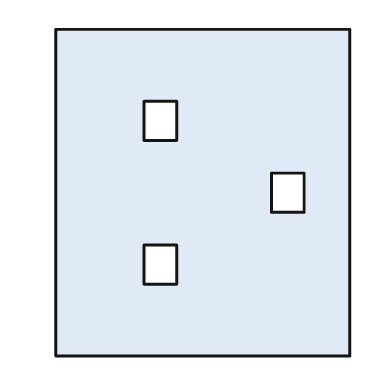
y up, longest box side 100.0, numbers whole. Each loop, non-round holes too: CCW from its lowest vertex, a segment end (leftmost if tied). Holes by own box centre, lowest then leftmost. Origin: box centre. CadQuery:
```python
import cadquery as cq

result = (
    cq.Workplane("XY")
    .moveTo(-45.0, -50.0)
    .lineTo(45.0, -50.0)
    .lineTo(45.0, 50.0)
    .lineTo(-45.0, 50.0)
    .close()
    .moveTo(-18.0, -28.0)
    .lineTo(-8.0, -28.0)
    .lineTo(-8.0, -16.0)
    .lineTo(-18.0, -16.0)
    .close()
    .moveTo(21.0, -6.0)
    .lineTo(31.0, -6.0)
    .lineTo(31.0, 6.0)
    .lineTo(21.0, 6.0)
    .close()
    .moveTo(-18.0, 16.0)
    .lineTo(-8.0, 16.0)
    .lineTo(-8.0, 28.0)
    .lineTo(-18.0, 28.0)
    .close()
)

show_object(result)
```